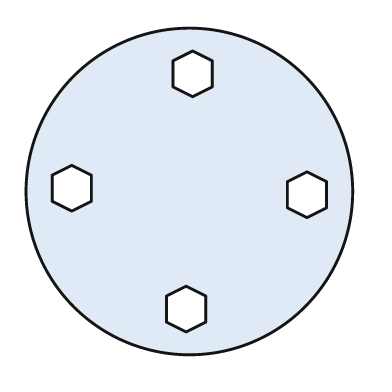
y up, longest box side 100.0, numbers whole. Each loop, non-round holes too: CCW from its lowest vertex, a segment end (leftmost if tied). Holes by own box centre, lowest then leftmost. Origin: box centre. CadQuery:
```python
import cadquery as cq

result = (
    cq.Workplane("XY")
    .moveTo(0.0, 0.0)
    .circle(50.0)
    .moveTo(-1.0, -43.0)
    .lineTo(5.0, -40.0)
    .lineTo(5.0, -32.0)
    .lineTo(-1.0, -29.0)
    .lineTo(-7.0, -32.0)
    .lineTo(-7.0, -40.0)
    .close()
    .moveTo(36.0, -8.0)
    .lineTo(42.0, -5.0)
    .lineTo(42.0, 3.0)
    .lineTo(36.0, 6.0)
    .lineTo(30.0, 3.0)
    .lineTo(30.0, -5.0)
    .close()
    .moveTo(-36.0, -6.0)
    .lineTo(-30.0, -3.0)
    .lineTo(-30.0, 5.0)
    .lineTo(-36.0, 8.0)
    .lineTo(-42.0, 5.0)
    .lineTo(-42.0, -3.0)
    .close()
    .moveTo(1.0, 29.0)
    .lineTo(7.0, 32.0)
    .lineTo(7.0, 40.0)
    .lineTo(1.0, 43.0)
    .lineTo(-5.0, 40.0)
    .lineTo(-5.0, 32.0)
    .close()
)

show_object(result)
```